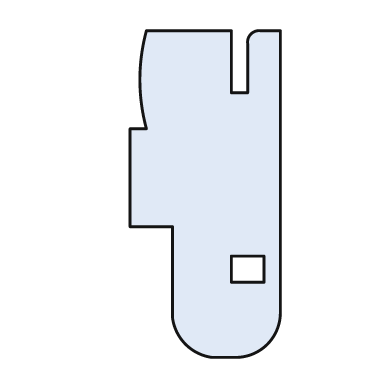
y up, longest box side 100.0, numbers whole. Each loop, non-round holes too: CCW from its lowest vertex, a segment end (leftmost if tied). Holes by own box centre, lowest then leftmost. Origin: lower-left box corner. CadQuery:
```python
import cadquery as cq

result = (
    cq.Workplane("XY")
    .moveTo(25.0, 0.0)
    .lineTo(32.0, 0.0)
    .threePointArc((42.0, 4.0), (46.0, 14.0))
    .lineTo(46.0, 100.0)
    .lineTo(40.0, 100.0)
    .threePointArc((37.0, 99.0), (36.0, 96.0))
    .lineTo(36.0, 81.0)
    .lineTo(31.0, 81.0)
    .lineTo(31.0, 100.0)
    .lineTo(5.0, 100.0)
    .threePointArc((3.0, 85.0), (5.0, 70.0))
    .lineTo(0.0, 70.0)
    .lineTo(0.0, 40.0)
    .lineTo(13.0, 40.0)
    .lineTo(13.0, 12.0)
    .threePointArc((17.0, 4.0), (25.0, 0.0))
    .close()
    .moveTo(31.0, 23.0)
    .lineTo(41.0, 23.0)
    .lineTo(41.0, 31.0)
    .lineTo(31.0, 31.0)
    .close()
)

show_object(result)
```